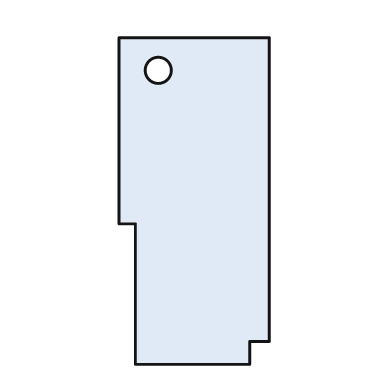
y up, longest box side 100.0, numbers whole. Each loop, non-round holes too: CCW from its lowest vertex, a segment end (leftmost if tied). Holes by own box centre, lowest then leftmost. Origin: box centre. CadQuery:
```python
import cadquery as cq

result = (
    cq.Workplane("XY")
    .moveTo(-18.0, -50.0)
    .lineTo(17.0, -50.0)
    .lineTo(17.0, -43.0)
    .lineTo(23.0, -43.0)
    .lineTo(23.0, 50.0)
    .lineTo(-23.0, 50.0)
    .lineTo(-23.0, -7.0)
    .lineTo(-18.0, -7.0)
    .close()
    .moveTo(-11.0, 40.0)
    .circle(4.0)
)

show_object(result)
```